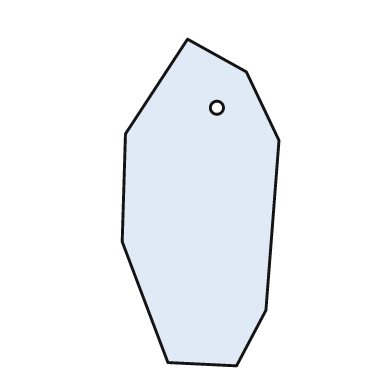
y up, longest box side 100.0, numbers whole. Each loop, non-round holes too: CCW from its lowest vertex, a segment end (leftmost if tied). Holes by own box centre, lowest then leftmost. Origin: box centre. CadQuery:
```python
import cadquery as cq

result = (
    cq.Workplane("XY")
    .moveTo(11.0, -50.0)
    .lineTo(20.0, -33.0)
    .lineTo(24.0, 19.0)
    .lineTo(14.0, 40.0)
    .lineTo(-4.0, 50.0)
    .lineTo(-23.0, 21.0)
    .lineTo(-24.0, -12.0)
    .lineTo(-10.0, -49.0)
    .close()
    .moveTo(5.0, 29.0)
    .circle(2.0)
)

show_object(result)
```